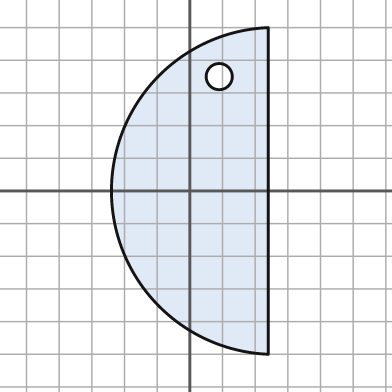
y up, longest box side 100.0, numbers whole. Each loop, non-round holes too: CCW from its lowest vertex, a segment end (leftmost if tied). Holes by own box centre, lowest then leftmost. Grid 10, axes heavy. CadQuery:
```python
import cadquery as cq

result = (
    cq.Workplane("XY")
    .moveTo(24.0, -50.0)
    .lineTo(24.0, 50.0)
    .threePointArc((-24.0, 0.0), (24.0, -50.0))
    .close()
    .moveTo(9.0, 35.0)
    .circle(4.0)
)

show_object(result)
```